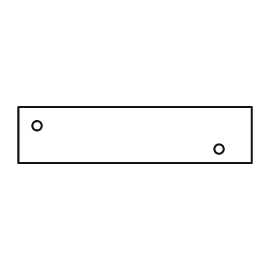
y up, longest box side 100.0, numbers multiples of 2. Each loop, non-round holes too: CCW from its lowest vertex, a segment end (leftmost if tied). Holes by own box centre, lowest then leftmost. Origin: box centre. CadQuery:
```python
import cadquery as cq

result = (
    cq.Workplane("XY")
    .moveTo(-50.0, -12.0)
    .lineTo(50.0, -12.0)
    .lineTo(50.0, 12.0)
    .lineTo(-50.0, 12.0)
    .close()
    .moveTo(36.0, -6.0)
    .circle(2.0)
    .moveTo(-42.0, 4.0)
    .circle(2.0)
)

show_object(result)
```